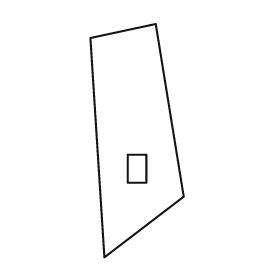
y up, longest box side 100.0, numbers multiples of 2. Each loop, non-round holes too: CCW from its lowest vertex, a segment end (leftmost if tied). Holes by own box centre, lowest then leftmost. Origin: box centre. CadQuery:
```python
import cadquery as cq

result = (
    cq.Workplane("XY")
    .moveTo(-14.0, -50.0)
    .lineTo(20.0, -24.0)
    .lineTo(8.0, 50.0)
    .lineTo(-20.0, 44.0)
    .close()
    .moveTo(-4.0, -18.0)
    .lineTo(4.0, -18.0)
    .lineTo(4.0, -6.0)
    .lineTo(-4.0, -6.0)
    .close()
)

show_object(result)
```